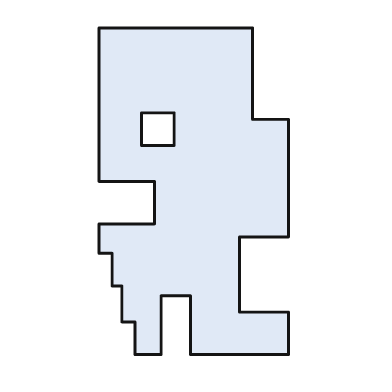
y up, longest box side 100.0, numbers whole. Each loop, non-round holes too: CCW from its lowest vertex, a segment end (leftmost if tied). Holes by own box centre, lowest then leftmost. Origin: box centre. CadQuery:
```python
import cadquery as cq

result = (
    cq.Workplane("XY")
    .moveTo(-18.0, -50.0)
    .lineTo(-10.0, -50.0)
    .lineTo(-10.0, -32.0)
    .lineTo(-1.0, -32.0)
    .lineTo(-1.0, -50.0)
    .lineTo(29.0, -50.0)
    .lineTo(29.0, -37.0)
    .lineTo(14.0, -37.0)
    .lineTo(14.0, -14.0)
    .lineTo(29.0, -14.0)
    .lineTo(29.0, 22.0)
    .lineTo(18.0, 22.0)
    .lineTo(18.0, 50.0)
    .lineTo(-29.0, 50.0)
    .lineTo(-29.0, 3.0)
    .lineTo(-12.0, 3.0)
    .lineTo(-12.0, -10.0)
    .lineTo(-29.0, -10.0)
    .lineTo(-29.0, -19.0)
    .lineTo(-25.0, -19.0)
    .lineTo(-25.0, -29.0)
    .lineTo(-22.0, -29.0)
    .lineTo(-22.0, -40.0)
    .lineTo(-18.0, -40.0)
    .close()
    .moveTo(-16.0, 14.0)
    .lineTo(-6.0, 14.0)
    .lineTo(-6.0, 24.0)
    .lineTo(-16.0, 24.0)
    .close()
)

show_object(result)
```